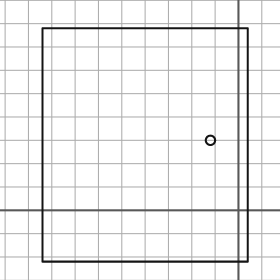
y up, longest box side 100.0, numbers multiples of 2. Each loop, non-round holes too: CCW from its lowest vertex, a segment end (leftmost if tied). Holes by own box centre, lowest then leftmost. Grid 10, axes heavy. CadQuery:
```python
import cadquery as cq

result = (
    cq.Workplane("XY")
    .moveTo(-84.0, -22.0)
    .lineTo(4.0, -22.0)
    .lineTo(4.0, 78.0)
    .lineTo(-84.0, 78.0)
    .close()
    .moveTo(-12.0, 30.0)
    .circle(2.0)
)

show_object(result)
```